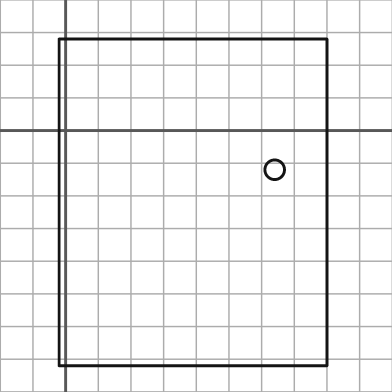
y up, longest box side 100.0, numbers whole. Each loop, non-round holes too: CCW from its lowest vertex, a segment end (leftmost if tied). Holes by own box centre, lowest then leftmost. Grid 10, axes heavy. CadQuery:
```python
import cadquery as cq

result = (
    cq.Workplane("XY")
    .moveTo(-2.0, -72.0)
    .lineTo(80.0, -72.0)
    .lineTo(80.0, 28.0)
    .lineTo(-2.0, 28.0)
    .close()
    .moveTo(64.0, -12.0)
    .circle(3.0)
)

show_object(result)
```